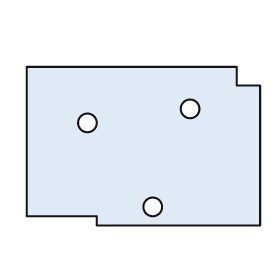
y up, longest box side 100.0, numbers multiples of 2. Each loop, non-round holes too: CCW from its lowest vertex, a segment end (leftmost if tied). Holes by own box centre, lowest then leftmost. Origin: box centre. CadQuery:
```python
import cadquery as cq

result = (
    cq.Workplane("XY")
    .moveTo(-20.0, -34.0)
    .lineTo(50.0, -34.0)
    .lineTo(50.0, 26.0)
    .lineTo(40.0, 26.0)
    .lineTo(40.0, 34.0)
    .lineTo(-50.0, 34.0)
    .lineTo(-50.0, -30.0)
    .lineTo(-20.0, -30.0)
    .close()
    .moveTo(4.0, -26.0)
    .circle(4.0)
    .moveTo(-24.0, 10.0)
    .circle(4.0)
    .moveTo(20.0, 16.0)
    .circle(4.0)
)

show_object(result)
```